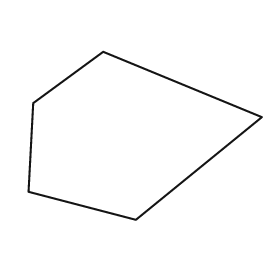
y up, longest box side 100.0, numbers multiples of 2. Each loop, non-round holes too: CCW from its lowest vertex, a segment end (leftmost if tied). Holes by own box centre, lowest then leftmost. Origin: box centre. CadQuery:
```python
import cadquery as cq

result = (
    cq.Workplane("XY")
    .moveTo(-4.0, -36.0)
    .lineTo(50.0, 8.0)
    .lineTo(-18.0, 36.0)
    .lineTo(-48.0, 14.0)
    .lineTo(-50.0, -24.0)
    .close()
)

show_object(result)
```